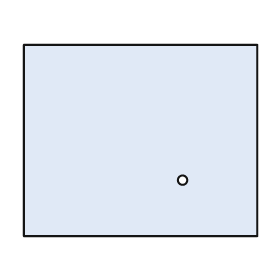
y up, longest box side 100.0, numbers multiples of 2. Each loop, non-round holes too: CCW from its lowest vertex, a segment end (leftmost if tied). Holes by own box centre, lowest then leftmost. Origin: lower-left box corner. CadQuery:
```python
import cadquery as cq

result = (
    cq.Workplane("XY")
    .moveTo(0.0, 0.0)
    .lineTo(100.0, 0.0)
    .lineTo(100.0, 82.0)
    .lineTo(0.0, 82.0)
    .close()
    .moveTo(68.0, 24.0)
    .circle(2.0)
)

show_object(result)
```